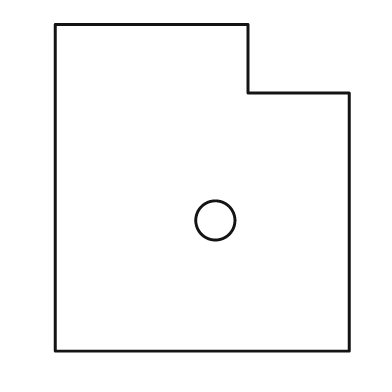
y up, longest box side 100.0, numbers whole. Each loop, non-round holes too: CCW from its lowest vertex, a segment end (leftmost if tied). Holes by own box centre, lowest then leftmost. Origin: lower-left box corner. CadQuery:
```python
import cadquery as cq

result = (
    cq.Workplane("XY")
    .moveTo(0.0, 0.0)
    .lineTo(90.0, 0.0)
    .lineTo(90.0, 79.0)
    .lineTo(59.0, 79.0)
    .lineTo(59.0, 100.0)
    .lineTo(0.0, 100.0)
    .close()
    .moveTo(49.0, 40.0)
    .circle(6.0)
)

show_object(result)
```